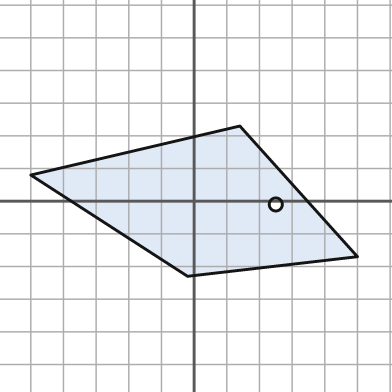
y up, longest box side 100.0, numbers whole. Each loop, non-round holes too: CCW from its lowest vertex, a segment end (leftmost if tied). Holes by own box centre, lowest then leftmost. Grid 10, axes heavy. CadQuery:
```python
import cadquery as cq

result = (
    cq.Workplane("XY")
    .moveTo(-2.0, -23.0)
    .lineTo(50.0, -17.0)
    .lineTo(14.0, 23.0)
    .lineTo(-50.0, 8.0)
    .close()
    .moveTo(25.0, -1.0)
    .circle(2.0)
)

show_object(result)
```